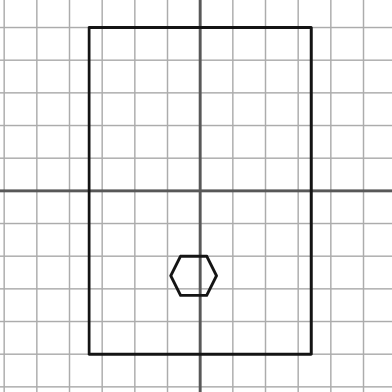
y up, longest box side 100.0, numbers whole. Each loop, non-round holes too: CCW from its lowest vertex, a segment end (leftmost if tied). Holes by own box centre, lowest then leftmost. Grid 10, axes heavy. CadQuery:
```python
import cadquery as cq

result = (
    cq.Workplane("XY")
    .moveTo(-34.0, -50.0)
    .lineTo(34.0, -50.0)
    .lineTo(34.0, 50.0)
    .lineTo(-34.0, 50.0)
    .close()
    .moveTo(-6.0, -32.0)
    .lineTo(2.0, -32.0)
    .lineTo(5.0, -26.0)
    .lineTo(2.0, -20.0)
    .lineTo(-6.0, -20.0)
    .lineTo(-9.0, -26.0)
    .close()
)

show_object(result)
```